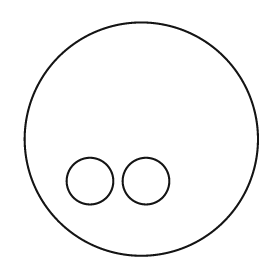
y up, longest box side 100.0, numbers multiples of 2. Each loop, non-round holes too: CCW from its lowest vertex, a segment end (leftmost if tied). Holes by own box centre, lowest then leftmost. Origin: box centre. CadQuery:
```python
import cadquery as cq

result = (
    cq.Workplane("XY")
    .moveTo(0.0, 0.0)
    .circle(50.0)
    .moveTo(-22.0, -18.0)
    .circle(10.0)
    .moveTo(2.0, -18.0)
    .circle(10.0)
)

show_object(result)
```